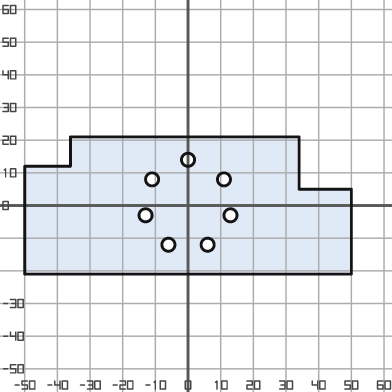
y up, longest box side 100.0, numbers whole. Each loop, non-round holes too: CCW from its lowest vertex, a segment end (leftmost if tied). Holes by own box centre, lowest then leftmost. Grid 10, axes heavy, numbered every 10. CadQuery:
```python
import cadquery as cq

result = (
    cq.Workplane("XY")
    .moveTo(-50.0, -21.0)
    .lineTo(50.0, -21.0)
    .lineTo(50.0, 5.0)
    .lineTo(34.0, 5.0)
    .lineTo(34.0, 21.0)
    .lineTo(-36.0, 21.0)
    .lineTo(-36.0, 12.0)
    .lineTo(-50.0, 12.0)
    .close()
    .moveTo(-6.0, -12.0)
    .circle(2.0)
    .moveTo(6.0, -12.0)
    .circle(2.0)
    .moveTo(-13.0, -3.0)
    .circle(2.0)
    .moveTo(13.0, -3.0)
    .circle(2.0)
    .moveTo(-11.0, 8.0)
    .circle(2.0)
    .moveTo(11.0, 8.0)
    .circle(2.0)
    .moveTo(0.0, 14.0)
    .circle(2.0)
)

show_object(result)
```